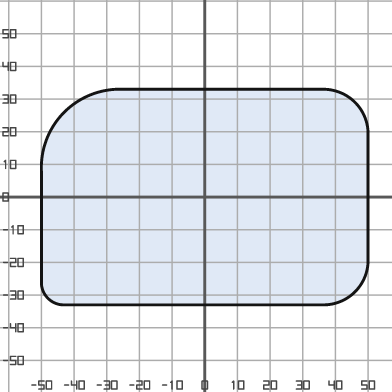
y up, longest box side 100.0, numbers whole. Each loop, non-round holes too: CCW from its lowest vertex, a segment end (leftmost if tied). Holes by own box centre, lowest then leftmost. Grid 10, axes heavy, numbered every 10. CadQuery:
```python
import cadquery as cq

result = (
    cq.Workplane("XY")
    .moveTo(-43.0, -33.0)
    .lineTo(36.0, -33.0)
    .threePointArc((46.0, -29.0), (50.0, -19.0))
    .lineTo(50.0, 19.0)
    .threePointArc((46.0, 29.0), (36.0, 33.0))
    .lineTo(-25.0, 33.0)
    .threePointArc((-43.0, 26.0), (-50.0, 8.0))
    .lineTo(-50.0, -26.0)
    .threePointArc((-48.0, -31.0), (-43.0, -33.0))
    .close()
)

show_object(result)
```